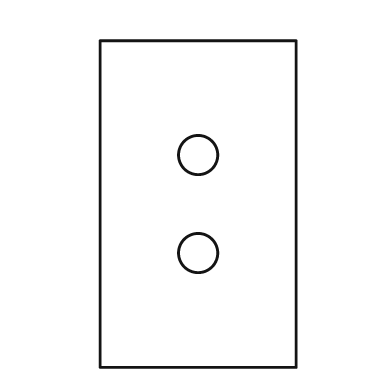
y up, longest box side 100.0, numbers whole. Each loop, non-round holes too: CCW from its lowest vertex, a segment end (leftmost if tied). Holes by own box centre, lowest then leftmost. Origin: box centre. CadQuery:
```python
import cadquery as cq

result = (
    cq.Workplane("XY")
    .moveTo(-30.0, -50.0)
    .lineTo(30.0, -50.0)
    .lineTo(30.0, 50.0)
    .lineTo(-30.0, 50.0)
    .close()
    .moveTo(0.0, -15.0)
    .circle(6.0)
    .moveTo(0.0, 15.0)
    .circle(6.0)
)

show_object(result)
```